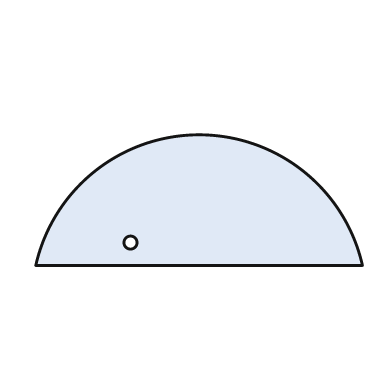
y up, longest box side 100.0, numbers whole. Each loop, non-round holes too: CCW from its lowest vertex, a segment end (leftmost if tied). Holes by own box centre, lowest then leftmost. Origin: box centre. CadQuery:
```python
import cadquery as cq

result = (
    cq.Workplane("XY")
    .moveTo(-50.0, -20.0)
    .lineTo(50.0, -20.0)
    .threePointArc((0.0, 20.0), (-50.0, -20.0))
    .close()
    .moveTo(-21.0, -13.0)
    .circle(2.0)
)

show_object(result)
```